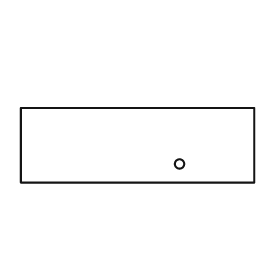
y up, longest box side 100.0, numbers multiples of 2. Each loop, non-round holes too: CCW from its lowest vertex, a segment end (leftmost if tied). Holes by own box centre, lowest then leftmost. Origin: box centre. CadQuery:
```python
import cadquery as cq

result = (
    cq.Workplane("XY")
    .moveTo(-50.0, -16.0)
    .lineTo(50.0, -16.0)
    .lineTo(50.0, 16.0)
    .lineTo(-50.0, 16.0)
    .close()
    .moveTo(18.0, -8.0)
    .circle(2.0)
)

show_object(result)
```